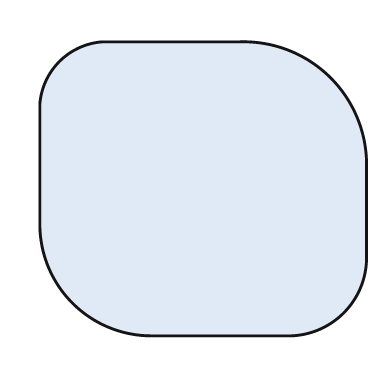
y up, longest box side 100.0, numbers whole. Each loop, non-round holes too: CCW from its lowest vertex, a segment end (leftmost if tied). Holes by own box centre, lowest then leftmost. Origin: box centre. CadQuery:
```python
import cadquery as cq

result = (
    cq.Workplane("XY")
    .moveTo(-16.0, -45.0)
    .lineTo(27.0, -45.0)
    .threePointArc((43.0, -38.0), (50.0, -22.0))
    .lineTo(50.0, 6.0)
    .threePointArc((39.0, 34.0), (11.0, 45.0))
    .lineTo(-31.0, 45.0)
    .threePointArc((-44.0, 39.0), (-50.0, 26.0))
    .lineTo(-50.0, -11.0)
    .threePointArc((-40.0, -35.0), (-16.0, -45.0))
    .close()
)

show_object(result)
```